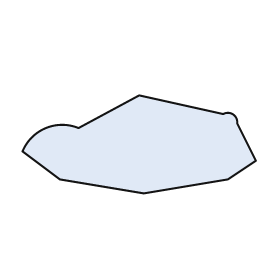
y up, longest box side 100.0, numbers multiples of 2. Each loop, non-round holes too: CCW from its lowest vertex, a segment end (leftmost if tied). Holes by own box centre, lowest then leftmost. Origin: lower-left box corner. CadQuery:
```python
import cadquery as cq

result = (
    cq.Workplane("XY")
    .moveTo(52.0, 0.0)
    .lineTo(88.0, 6.0)
    .lineTo(100.0, 14.0)
    .lineTo(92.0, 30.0)
    .threePointArc((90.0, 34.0), (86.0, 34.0))
    .lineTo(50.0, 42.0)
    .lineTo(24.0, 28.0)
    .threePointArc((10.0, 28.0), (0.0, 18.0))
    .lineTo(16.0, 6.0)
    .close()
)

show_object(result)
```